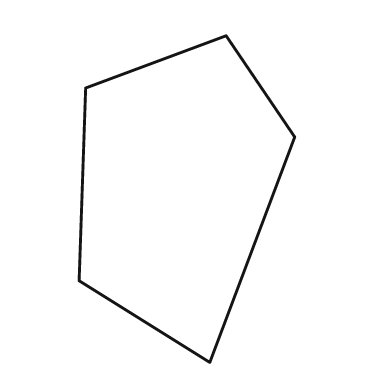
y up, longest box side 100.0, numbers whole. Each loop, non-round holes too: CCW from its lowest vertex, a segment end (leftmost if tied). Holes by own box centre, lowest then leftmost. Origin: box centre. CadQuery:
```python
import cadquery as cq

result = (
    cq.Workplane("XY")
    .moveTo(7.0, -50.0)
    .lineTo(33.0, 19.0)
    .lineTo(12.0, 50.0)
    .lineTo(-31.0, 34.0)
    .lineTo(-33.0, -25.0)
    .close()
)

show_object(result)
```